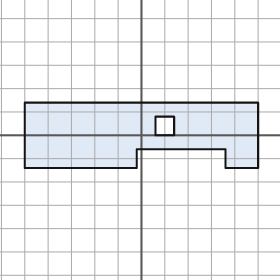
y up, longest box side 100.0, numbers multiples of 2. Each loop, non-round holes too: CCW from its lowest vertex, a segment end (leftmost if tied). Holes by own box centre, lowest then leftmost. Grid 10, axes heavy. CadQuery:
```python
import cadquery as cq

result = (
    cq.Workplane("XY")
    .moveTo(-50.0, -14.0)
    .lineTo(-2.0, -14.0)
    .lineTo(-2.0, -6.0)
    .lineTo(36.0, -6.0)
    .lineTo(36.0, -14.0)
    .lineTo(50.0, -14.0)
    .lineTo(50.0, 14.0)
    .lineTo(-50.0, 14.0)
    .close()
    .moveTo(6.0, 0.0)
    .lineTo(14.0, 0.0)
    .lineTo(14.0, 8.0)
    .lineTo(6.0, 8.0)
    .close()
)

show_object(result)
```